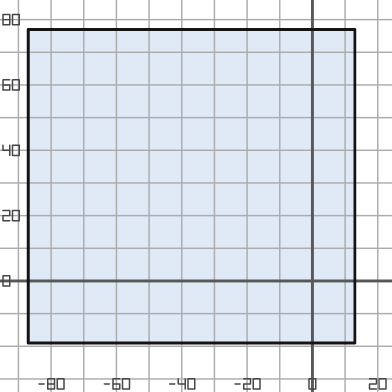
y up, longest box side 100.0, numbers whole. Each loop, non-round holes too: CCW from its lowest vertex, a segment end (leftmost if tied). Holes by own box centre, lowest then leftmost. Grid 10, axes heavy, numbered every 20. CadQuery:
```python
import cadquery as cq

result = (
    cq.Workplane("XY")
    .moveTo(-87.0, -19.0)
    .lineTo(13.0, -19.0)
    .lineTo(13.0, 77.0)
    .lineTo(-87.0, 77.0)
    .close()
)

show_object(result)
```